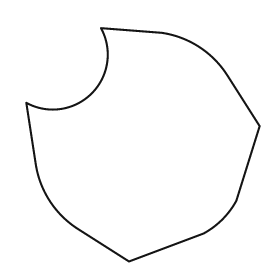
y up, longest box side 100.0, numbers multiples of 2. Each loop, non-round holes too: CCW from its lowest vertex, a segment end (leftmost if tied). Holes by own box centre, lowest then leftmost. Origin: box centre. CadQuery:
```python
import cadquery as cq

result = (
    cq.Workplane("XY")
    .moveTo(-6.0, -50.0)
    .lineTo(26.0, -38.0)
    .threePointArc((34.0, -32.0), (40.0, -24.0))
    .lineTo(50.0, 8.0)
    .lineTo(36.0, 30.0)
    .threePointArc((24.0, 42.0), (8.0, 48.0))
    .lineTo(-18.0, 50.0)
    .threePointArc((-22.0, 22.0), (-50.0, 18.0))
    .lineTo(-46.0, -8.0)
    .threePointArc((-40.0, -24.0), (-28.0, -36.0))
    .close()
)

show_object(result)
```